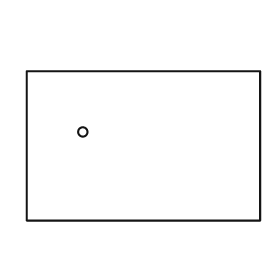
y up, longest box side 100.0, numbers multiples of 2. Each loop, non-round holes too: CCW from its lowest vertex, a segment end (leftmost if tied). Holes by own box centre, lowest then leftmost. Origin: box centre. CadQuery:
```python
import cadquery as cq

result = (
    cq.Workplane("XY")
    .moveTo(-50.0, -32.0)
    .lineTo(50.0, -32.0)
    .lineTo(50.0, 32.0)
    .lineTo(-50.0, 32.0)
    .close()
    .moveTo(-26.0, 6.0)
    .circle(2.0)
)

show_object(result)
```